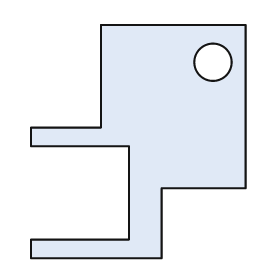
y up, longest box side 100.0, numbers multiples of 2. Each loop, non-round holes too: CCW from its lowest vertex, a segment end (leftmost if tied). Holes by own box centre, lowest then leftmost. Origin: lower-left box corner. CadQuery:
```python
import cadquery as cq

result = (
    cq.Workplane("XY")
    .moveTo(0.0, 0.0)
    .lineTo(56.0, 0.0)
    .lineTo(56.0, 30.0)
    .lineTo(92.0, 30.0)
    .lineTo(92.0, 100.0)
    .lineTo(30.0, 100.0)
    .lineTo(30.0, 56.0)
    .lineTo(0.0, 56.0)
    .lineTo(0.0, 48.0)
    .lineTo(42.0, 48.0)
    .lineTo(42.0, 8.0)
    .lineTo(0.0, 8.0)
    .close()
    .moveTo(78.0, 84.0)
    .circle(8.0)
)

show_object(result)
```